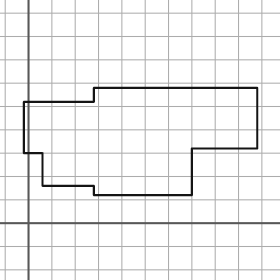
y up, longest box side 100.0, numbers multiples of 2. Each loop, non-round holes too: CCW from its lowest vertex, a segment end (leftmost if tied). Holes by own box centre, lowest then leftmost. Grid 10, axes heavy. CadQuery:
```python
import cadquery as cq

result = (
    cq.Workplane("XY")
    .moveTo(28.0, 12.0)
    .lineTo(70.0, 12.0)
    .lineTo(70.0, 32.0)
    .lineTo(98.0, 32.0)
    .lineTo(98.0, 58.0)
    .lineTo(28.0, 58.0)
    .lineTo(28.0, 52.0)
    .lineTo(-2.0, 52.0)
    .lineTo(-2.0, 30.0)
    .lineTo(6.0, 30.0)
    .lineTo(6.0, 16.0)
    .lineTo(28.0, 16.0)
    .close()
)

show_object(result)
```